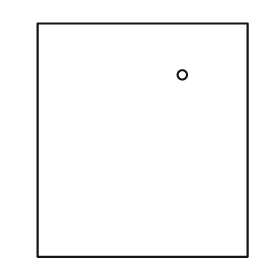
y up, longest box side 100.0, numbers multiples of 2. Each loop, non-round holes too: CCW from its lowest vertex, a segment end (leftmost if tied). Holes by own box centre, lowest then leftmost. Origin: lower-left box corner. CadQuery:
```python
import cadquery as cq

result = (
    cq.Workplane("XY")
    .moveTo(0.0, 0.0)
    .lineTo(90.0, 0.0)
    .lineTo(90.0, 100.0)
    .lineTo(0.0, 100.0)
    .close()
    .moveTo(62.0, 78.0)
    .circle(2.0)
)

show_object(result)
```